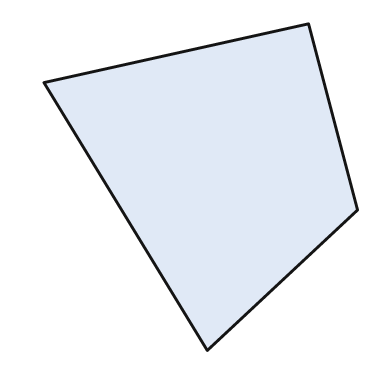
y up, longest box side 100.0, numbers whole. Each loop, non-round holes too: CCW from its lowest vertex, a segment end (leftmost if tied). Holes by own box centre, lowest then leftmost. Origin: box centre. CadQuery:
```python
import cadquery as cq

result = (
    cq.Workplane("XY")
    .moveTo(2.0, -50.0)
    .lineTo(48.0, -7.0)
    .lineTo(33.0, 50.0)
    .lineTo(-48.0, 32.0)
    .close()
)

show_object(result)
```